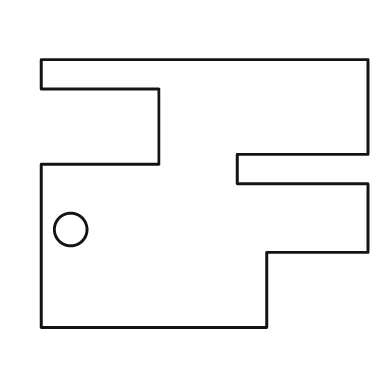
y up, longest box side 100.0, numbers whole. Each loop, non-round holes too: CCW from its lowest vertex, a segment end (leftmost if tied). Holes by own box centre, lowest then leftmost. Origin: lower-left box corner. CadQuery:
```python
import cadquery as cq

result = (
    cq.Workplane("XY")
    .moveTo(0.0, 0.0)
    .lineTo(69.0, 0.0)
    .lineTo(69.0, 23.0)
    .lineTo(100.0, 23.0)
    .lineTo(100.0, 44.0)
    .lineTo(60.0, 44.0)
    .lineTo(60.0, 53.0)
    .lineTo(100.0, 53.0)
    .lineTo(100.0, 82.0)
    .lineTo(0.0, 82.0)
    .lineTo(0.0, 73.0)
    .lineTo(36.0, 73.0)
    .lineTo(36.0, 50.0)
    .lineTo(0.0, 50.0)
    .close()
    .moveTo(9.0, 30.0)
    .circle(5.0)
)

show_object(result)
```